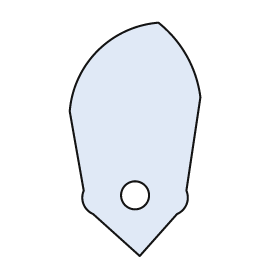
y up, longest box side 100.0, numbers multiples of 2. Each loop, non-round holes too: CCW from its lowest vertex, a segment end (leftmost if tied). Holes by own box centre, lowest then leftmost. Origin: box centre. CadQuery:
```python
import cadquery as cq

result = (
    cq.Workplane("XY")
    .moveTo(2.0, -50.0)
    .lineTo(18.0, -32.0)
    .threePointArc((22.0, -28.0), (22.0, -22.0))
    .lineTo(28.0, 18.0)
    .threePointArc((22.0, 36.0), (10.0, 50.0))
    .threePointArc((-16.0, 38.0), (-28.0, 12.0))
    .lineTo(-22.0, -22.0)
    .threePointArc((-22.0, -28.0), (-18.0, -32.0))
    .close()
    .moveTo(0.0, -24.0)
    .circle(6.0)
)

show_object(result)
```